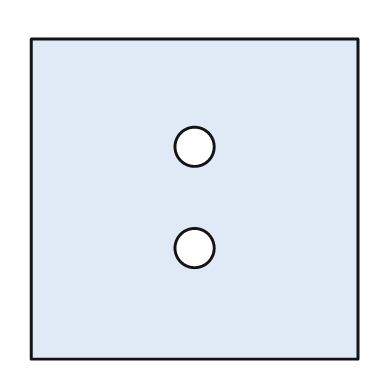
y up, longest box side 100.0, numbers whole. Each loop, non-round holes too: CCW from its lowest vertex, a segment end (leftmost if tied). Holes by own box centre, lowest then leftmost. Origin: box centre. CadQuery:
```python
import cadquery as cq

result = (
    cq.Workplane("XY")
    .moveTo(-50.0, -49.0)
    .lineTo(50.0, -49.0)
    .lineTo(50.0, 49.0)
    .lineTo(-50.0, 49.0)
    .close()
    .moveTo(0.0, -15.0)
    .circle(6.0)
    .moveTo(0.0, 16.0)
    .circle(6.0)
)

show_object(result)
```